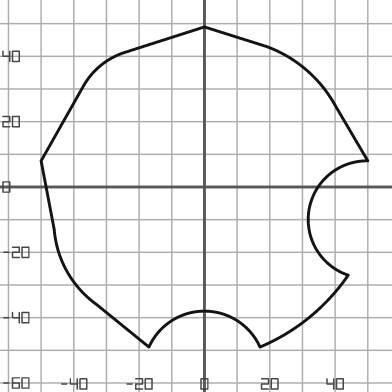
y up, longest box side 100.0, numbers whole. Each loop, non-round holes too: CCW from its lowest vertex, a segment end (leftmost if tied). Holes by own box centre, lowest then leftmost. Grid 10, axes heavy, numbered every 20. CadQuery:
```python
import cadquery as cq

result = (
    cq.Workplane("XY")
    .moveTo(-17.0, -49.0)
    .threePointArc((0.0, -38.0), (17.0, -49.0))
    .threePointArc((32.0, -40.0), (44.0, -27.0))
    .threePointArc((32.0, -7.0), (50.0, 8.0))
    .lineTo(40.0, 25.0)
    .threePointArc((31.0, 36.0), (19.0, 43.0))
    .lineTo(0.0, 49.0)
    .lineTo(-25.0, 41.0)
    .threePointArc((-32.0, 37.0), (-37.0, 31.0))
    .lineTo(-50.0, 8.0)
    .lineTo(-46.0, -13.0)
    .threePointArc((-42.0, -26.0), (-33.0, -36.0))
    .close()
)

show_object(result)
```